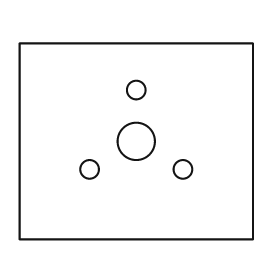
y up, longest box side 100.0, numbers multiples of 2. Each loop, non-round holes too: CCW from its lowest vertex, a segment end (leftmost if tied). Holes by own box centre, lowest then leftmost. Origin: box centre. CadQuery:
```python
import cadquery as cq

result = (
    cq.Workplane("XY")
    .moveTo(-50.0, -42.0)
    .lineTo(50.0, -42.0)
    .lineTo(50.0, 42.0)
    .lineTo(-50.0, 42.0)
    .close()
    .moveTo(-20.0, -12.0)
    .circle(4.0)
    .moveTo(20.0, -12.0)
    .circle(4.0)
    .moveTo(0.0, 0.0)
    .circle(8.0)
    .moveTo(0.0, 22.0)
    .circle(4.0)
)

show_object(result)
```